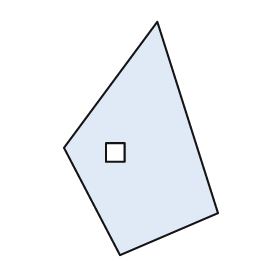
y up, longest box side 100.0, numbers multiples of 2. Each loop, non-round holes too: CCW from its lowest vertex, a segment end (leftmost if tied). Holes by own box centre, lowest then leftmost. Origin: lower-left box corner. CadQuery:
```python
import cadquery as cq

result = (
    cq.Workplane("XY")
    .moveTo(24.0, 0.0)
    .lineTo(66.0, 18.0)
    .lineTo(40.0, 100.0)
    .lineTo(0.0, 46.0)
    .close()
    .moveTo(18.0, 40.0)
    .lineTo(26.0, 40.0)
    .lineTo(26.0, 48.0)
    .lineTo(18.0, 48.0)
    .close()
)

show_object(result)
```